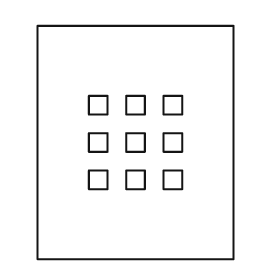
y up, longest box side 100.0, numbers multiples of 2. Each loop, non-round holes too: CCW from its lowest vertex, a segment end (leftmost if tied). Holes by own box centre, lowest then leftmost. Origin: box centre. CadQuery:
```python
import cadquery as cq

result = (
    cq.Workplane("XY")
    .moveTo(-42.0, -50.0)
    .lineTo(42.0, -50.0)
    .lineTo(42.0, 50.0)
    .lineTo(-42.0, 50.0)
    .close()
    .moveTo(-20.0, -20.0)
    .lineTo(-12.0, -20.0)
    .lineTo(-12.0, -12.0)
    .lineTo(-20.0, -12.0)
    .close()
    .moveTo(-4.0, -20.0)
    .lineTo(4.0, -20.0)
    .lineTo(4.0, -12.0)
    .lineTo(-4.0, -12.0)
    .close()
    .moveTo(12.0, -20.0)
    .lineTo(20.0, -20.0)
    .lineTo(20.0, -12.0)
    .lineTo(12.0, -12.0)
    .close()
    .moveTo(-20.0, -4.0)
    .lineTo(-12.0, -4.0)
    .lineTo(-12.0, 4.0)
    .lineTo(-20.0, 4.0)
    .close()
    .moveTo(-4.0, -4.0)
    .lineTo(4.0, -4.0)
    .lineTo(4.0, 4.0)
    .lineTo(-4.0, 4.0)
    .close()
    .moveTo(12.0, -4.0)
    .lineTo(20.0, -4.0)
    .lineTo(20.0, 4.0)
    .lineTo(12.0, 4.0)
    .close()
    .moveTo(-20.0, 12.0)
    .lineTo(-12.0, 12.0)
    .lineTo(-12.0, 20.0)
    .lineTo(-20.0, 20.0)
    .close()
    .moveTo(-4.0, 12.0)
    .lineTo(4.0, 12.0)
    .lineTo(4.0, 20.0)
    .lineTo(-4.0, 20.0)
    .close()
    .moveTo(12.0, 12.0)
    .lineTo(20.0, 12.0)
    .lineTo(20.0, 20.0)
    .lineTo(12.0, 20.0)
    .close()
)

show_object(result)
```